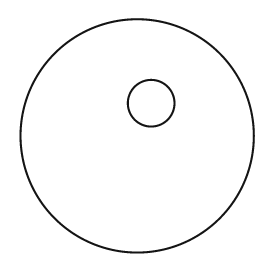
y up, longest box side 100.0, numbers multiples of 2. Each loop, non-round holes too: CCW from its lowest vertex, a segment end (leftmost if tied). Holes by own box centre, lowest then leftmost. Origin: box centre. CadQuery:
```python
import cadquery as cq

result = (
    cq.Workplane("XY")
    .moveTo(0.0, 0.0)
    .circle(50.0)
    .moveTo(6.0, 14.0)
    .circle(10.0)
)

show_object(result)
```